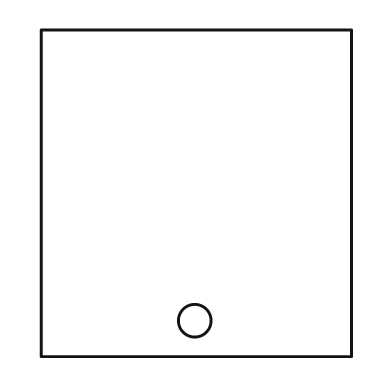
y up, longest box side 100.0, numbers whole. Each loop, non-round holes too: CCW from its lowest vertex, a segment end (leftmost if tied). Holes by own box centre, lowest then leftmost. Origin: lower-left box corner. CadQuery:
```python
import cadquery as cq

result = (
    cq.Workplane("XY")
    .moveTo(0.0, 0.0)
    .lineTo(95.0, 0.0)
    .lineTo(95.0, 100.0)
    .lineTo(0.0, 100.0)
    .close()
    .moveTo(47.0, 11.0)
    .circle(5.0)
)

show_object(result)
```